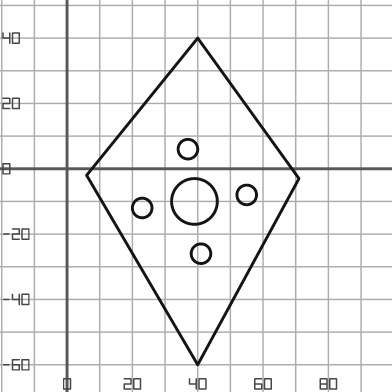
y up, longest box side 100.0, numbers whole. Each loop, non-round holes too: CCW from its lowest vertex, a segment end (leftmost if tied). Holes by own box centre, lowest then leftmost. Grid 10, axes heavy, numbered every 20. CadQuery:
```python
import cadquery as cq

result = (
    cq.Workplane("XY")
    .moveTo(40.0, -60.0)
    .lineTo(71.0, -3.0)
    .lineTo(40.0, 40.0)
    .lineTo(6.0, -2.0)
    .close()
    .moveTo(41.0, -26.0)
    .circle(3.0)
    .moveTo(23.0, -12.0)
    .circle(3.0)
    .moveTo(39.0, -10.0)
    .circle(7.0)
    .moveTo(55.0, -8.0)
    .circle(3.0)
    .moveTo(37.0, 6.0)
    .circle(3.0)
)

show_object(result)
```